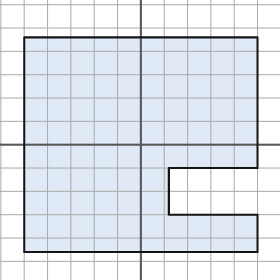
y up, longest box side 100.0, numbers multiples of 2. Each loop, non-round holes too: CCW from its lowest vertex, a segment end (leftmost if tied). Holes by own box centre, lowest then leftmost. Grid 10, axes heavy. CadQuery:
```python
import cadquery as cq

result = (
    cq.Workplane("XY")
    .moveTo(-50.0, -46.0)
    .lineTo(50.0, -46.0)
    .lineTo(50.0, -30.0)
    .lineTo(12.0, -30.0)
    .lineTo(12.0, -10.0)
    .lineTo(50.0, -10.0)
    .lineTo(50.0, 46.0)
    .lineTo(-50.0, 46.0)
    .close()
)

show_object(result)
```